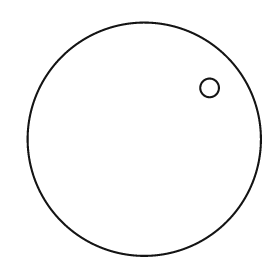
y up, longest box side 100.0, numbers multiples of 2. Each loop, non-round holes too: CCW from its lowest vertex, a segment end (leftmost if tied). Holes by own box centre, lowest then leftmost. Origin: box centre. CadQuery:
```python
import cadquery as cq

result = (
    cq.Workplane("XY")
    .moveTo(0.0, 0.0)
    .circle(50.0)
    .moveTo(28.0, 22.0)
    .circle(4.0)
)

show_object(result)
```